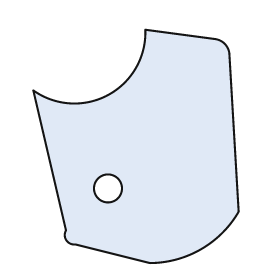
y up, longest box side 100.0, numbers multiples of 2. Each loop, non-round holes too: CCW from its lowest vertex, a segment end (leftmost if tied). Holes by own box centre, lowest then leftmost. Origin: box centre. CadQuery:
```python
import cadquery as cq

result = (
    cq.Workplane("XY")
    .moveTo(6.0, -50.0)
    .threePointArc((28.0, -44.0), (44.0, -28.0))
    .lineTo(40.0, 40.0)
    .threePointArc((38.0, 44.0), (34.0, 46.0))
    .lineTo(4.0, 50.0)
    .threePointArc((-12.0, 22.0), (-44.0, 24.0))
    .lineTo(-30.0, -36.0)
    .threePointArc((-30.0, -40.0), (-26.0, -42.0))
    .close()
    .moveTo(-12.0, -18.0)
    .circle(6.0)
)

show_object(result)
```